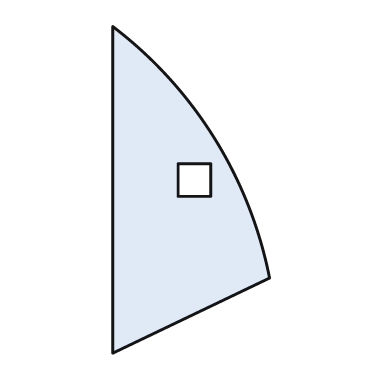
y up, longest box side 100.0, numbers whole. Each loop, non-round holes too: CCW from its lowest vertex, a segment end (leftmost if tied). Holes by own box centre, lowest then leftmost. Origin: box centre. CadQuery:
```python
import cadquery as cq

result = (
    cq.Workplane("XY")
    .moveTo(-24.0, -50.0)
    .lineTo(24.0, -27.0)
    .threePointArc((7.0, 16.0), (-24.0, 50.0))
    .close()
    .moveTo(-4.0, -2.0)
    .lineTo(6.0, -2.0)
    .lineTo(6.0, 8.0)
    .lineTo(-4.0, 8.0)
    .close()
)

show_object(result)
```